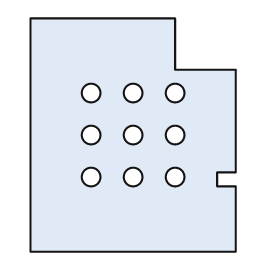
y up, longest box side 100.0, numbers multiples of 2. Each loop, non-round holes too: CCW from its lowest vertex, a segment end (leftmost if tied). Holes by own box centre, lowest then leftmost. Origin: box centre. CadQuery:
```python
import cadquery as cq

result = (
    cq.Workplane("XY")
    .moveTo(-44.0, -50.0)
    .lineTo(44.0, -50.0)
    .lineTo(44.0, -22.0)
    .lineTo(36.0, -22.0)
    .lineTo(36.0, -16.0)
    .lineTo(44.0, -16.0)
    .lineTo(44.0, 28.0)
    .lineTo(18.0, 28.0)
    .lineTo(18.0, 50.0)
    .lineTo(-44.0, 50.0)
    .close()
    .moveTo(-18.0, -18.0)
    .circle(4.0)
    .moveTo(0.0, -18.0)
    .circle(4.0)
    .moveTo(18.0, -18.0)
    .circle(4.0)
    .moveTo(-18.0, 0.0)
    .circle(4.0)
    .moveTo(0.0, 0.0)
    .circle(4.0)
    .moveTo(18.0, 0.0)
    .circle(4.0)
    .moveTo(-18.0, 18.0)
    .circle(4.0)
    .moveTo(0.0, 18.0)
    .circle(4.0)
    .moveTo(18.0, 18.0)
    .circle(4.0)
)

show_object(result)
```